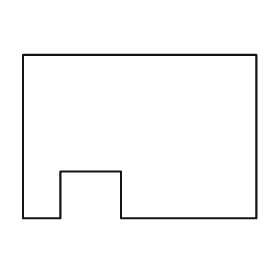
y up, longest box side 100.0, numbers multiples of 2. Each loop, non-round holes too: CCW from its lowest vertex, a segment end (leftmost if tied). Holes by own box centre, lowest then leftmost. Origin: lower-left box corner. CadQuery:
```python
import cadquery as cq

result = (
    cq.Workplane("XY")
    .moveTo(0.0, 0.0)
    .lineTo(16.0, 0.0)
    .lineTo(16.0, 20.0)
    .lineTo(42.0, 20.0)
    .lineTo(42.0, 0.0)
    .lineTo(100.0, 0.0)
    .lineTo(100.0, 70.0)
    .lineTo(0.0, 70.0)
    .close()
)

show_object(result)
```